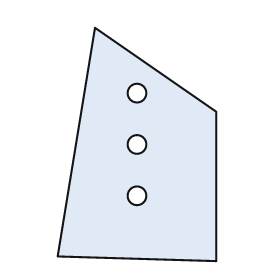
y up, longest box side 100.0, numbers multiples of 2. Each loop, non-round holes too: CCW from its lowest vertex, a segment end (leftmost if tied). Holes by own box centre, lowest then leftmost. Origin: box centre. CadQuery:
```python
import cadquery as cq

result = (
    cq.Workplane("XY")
    .moveTo(34.0, -50.0)
    .lineTo(34.0, 14.0)
    .lineTo(-18.0, 50.0)
    .lineTo(-34.0, -48.0)
    .close()
    .moveTo(0.0, -22.0)
    .circle(4.0)
    .moveTo(0.0, 0.0)
    .circle(4.0)
    .moveTo(0.0, 22.0)
    .circle(4.0)
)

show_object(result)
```